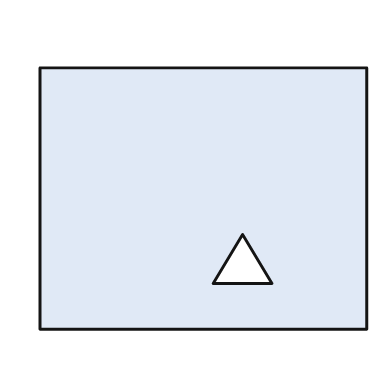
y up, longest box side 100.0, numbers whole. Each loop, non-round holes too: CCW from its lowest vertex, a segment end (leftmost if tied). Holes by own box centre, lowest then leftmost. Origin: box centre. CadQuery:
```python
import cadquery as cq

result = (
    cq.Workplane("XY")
    .moveTo(-50.0, -40.0)
    .lineTo(50.0, -40.0)
    .lineTo(50.0, 40.0)
    .lineTo(-50.0, 40.0)
    .close()
    .moveTo(3.0, -26.0)
    .lineTo(21.0, -26.0)
    .lineTo(12.0, -11.0)
    .close()
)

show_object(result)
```